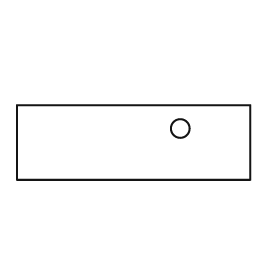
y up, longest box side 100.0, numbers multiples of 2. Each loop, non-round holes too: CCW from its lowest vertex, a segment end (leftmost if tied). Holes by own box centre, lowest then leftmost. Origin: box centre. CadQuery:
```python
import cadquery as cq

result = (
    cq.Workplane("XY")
    .moveTo(-50.0, -16.0)
    .lineTo(50.0, -16.0)
    .lineTo(50.0, 16.0)
    .lineTo(-50.0, 16.0)
    .close()
    .moveTo(20.0, 6.0)
    .circle(4.0)
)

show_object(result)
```